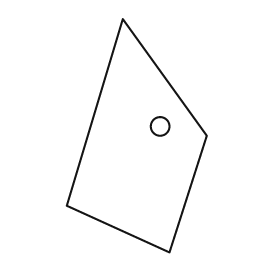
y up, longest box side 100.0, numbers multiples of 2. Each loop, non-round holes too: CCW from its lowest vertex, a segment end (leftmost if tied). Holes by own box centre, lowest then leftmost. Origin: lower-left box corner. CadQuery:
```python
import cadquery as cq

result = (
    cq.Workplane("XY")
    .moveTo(44.0, 0.0)
    .lineTo(60.0, 50.0)
    .lineTo(24.0, 100.0)
    .lineTo(0.0, 20.0)
    .close()
    .moveTo(40.0, 54.0)
    .circle(4.0)
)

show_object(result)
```